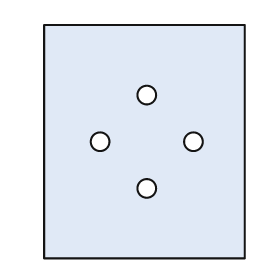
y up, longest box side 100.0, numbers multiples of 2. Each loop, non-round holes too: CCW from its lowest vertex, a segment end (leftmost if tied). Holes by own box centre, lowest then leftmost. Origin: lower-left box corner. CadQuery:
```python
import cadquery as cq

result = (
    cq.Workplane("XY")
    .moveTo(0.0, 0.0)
    .lineTo(86.0, 0.0)
    .lineTo(86.0, 100.0)
    .lineTo(0.0, 100.0)
    .close()
    .moveTo(44.0, 30.0)
    .circle(4.0)
    .moveTo(24.0, 50.0)
    .circle(4.0)
    .moveTo(64.0, 50.0)
    .circle(4.0)
    .moveTo(44.0, 70.0)
    .circle(4.0)
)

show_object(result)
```